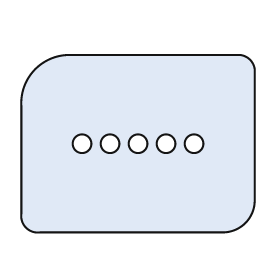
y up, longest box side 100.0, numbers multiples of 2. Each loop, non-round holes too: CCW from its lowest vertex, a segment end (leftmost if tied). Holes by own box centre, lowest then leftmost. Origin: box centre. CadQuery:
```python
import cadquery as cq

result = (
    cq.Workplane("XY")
    .moveTo(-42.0, -38.0)
    .lineTo(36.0, -38.0)
    .threePointArc((46.0, -34.0), (50.0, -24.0))
    .lineTo(50.0, 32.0)
    .threePointArc((48.0, 36.0), (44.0, 38.0))
    .lineTo(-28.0, 38.0)
    .threePointArc((-44.0, 32.0), (-50.0, 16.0))
    .lineTo(-50.0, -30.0)
    .threePointArc((-48.0, -36.0), (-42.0, -38.0))
    .close()
    .moveTo(-24.0, 0.0)
    .circle(4.0)
    .moveTo(-12.0, 0.0)
    .circle(4.0)
    .moveTo(0.0, 0.0)
    .circle(4.0)
    .moveTo(12.0, 0.0)
    .circle(4.0)
    .moveTo(24.0, 0.0)
    .circle(4.0)
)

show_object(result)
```